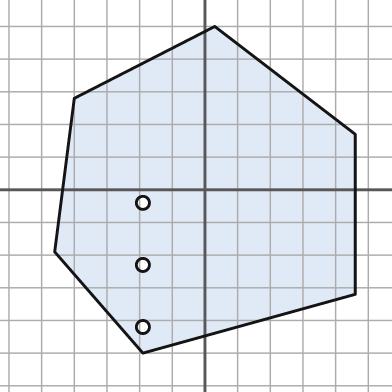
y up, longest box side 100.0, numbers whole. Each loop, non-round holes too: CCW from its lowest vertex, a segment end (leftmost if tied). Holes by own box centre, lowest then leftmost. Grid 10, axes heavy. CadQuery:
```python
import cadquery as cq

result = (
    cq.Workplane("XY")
    .moveTo(-19.0, -50.0)
    .lineTo(46.0, -32.0)
    .lineTo(46.0, 17.0)
    .lineTo(3.0, 50.0)
    .lineTo(-40.0, 28.0)
    .lineTo(-46.0, -19.0)
    .close()
    .moveTo(-19.0, -42.0)
    .circle(2.0)
    .moveTo(-19.0, -23.0)
    .circle(2.0)
    .moveTo(-19.0, -4.0)
    .circle(2.0)
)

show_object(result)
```